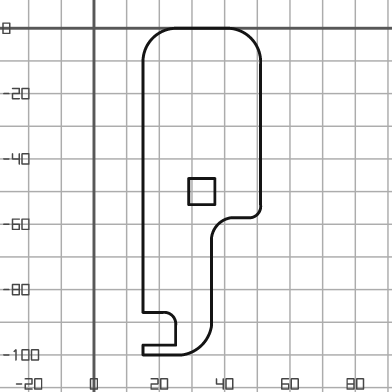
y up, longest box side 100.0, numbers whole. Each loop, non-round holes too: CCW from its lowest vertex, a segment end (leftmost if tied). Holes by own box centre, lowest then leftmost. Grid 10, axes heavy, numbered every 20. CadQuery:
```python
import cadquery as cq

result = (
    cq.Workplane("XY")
    .moveTo(15.0, -100.0)
    .lineTo(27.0, -100.0)
    .threePointArc((33.0, -97.0), (36.0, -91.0))
    .lineTo(36.0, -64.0)
    .threePointArc((38.0, -60.0), (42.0, -58.0))
    .lineTo(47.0, -58.0)
    .threePointArc((50.0, -57.0), (51.0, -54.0))
    .lineTo(51.0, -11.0)
    .threePointArc((48.0, -3.0), (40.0, 0.0))
    .lineTo(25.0, 0.0)
    .threePointArc((18.0, -3.0), (15.0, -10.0))
    .lineTo(15.0, -87.0)
    .lineTo(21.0, -87.0)
    .threePointArc((24.0, -88.0), (25.0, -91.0))
    .lineTo(25.0, -97.0)
    .lineTo(15.0, -97.0)
    .close()
    .moveTo(29.0, -54.0)
    .lineTo(37.0, -54.0)
    .lineTo(37.0, -46.0)
    .lineTo(29.0, -46.0)
    .close()
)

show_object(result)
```